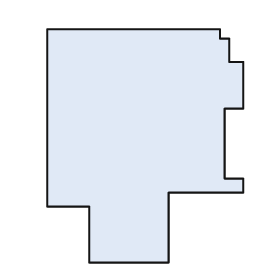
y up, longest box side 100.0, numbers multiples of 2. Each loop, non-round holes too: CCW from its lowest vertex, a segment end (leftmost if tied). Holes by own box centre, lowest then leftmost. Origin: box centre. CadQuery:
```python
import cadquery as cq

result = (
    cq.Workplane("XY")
    .moveTo(-24.0, -50.0)
    .lineTo(10.0, -50.0)
    .lineTo(10.0, -20.0)
    .lineTo(42.0, -20.0)
    .lineTo(42.0, -14.0)
    .lineTo(34.0, -14.0)
    .lineTo(34.0, 16.0)
    .lineTo(42.0, 16.0)
    .lineTo(42.0, 36.0)
    .lineTo(36.0, 36.0)
    .lineTo(36.0, 46.0)
    .lineTo(32.0, 46.0)
    .lineTo(32.0, 50.0)
    .lineTo(-42.0, 50.0)
    .lineTo(-42.0, -26.0)
    .lineTo(-24.0, -26.0)
    .close()
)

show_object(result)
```